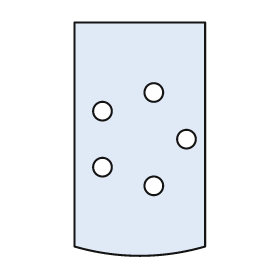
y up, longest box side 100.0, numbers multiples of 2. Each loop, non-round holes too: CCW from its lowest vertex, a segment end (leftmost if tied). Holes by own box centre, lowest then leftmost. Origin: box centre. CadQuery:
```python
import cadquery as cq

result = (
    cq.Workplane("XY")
    .moveTo(-28.0, -46.0)
    .threePointArc((0.0, -50.0), (28.0, -46.0))
    .lineTo(28.0, 50.0)
    .lineTo(-28.0, 50.0)
    .close()
    .moveTo(6.0, -20.0)
    .circle(4.0)
    .moveTo(-16.0, -12.0)
    .circle(4.0)
    .moveTo(20.0, 0.0)
    .circle(4.0)
    .moveTo(-16.0, 12.0)
    .circle(4.0)
    .moveTo(6.0, 20.0)
    .circle(4.0)
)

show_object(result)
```